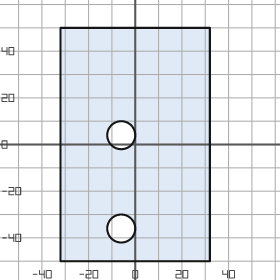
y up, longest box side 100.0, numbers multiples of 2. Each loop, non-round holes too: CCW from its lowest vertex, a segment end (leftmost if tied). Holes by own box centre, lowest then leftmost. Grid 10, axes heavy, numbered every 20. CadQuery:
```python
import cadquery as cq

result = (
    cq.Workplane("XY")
    .moveTo(-32.0, -50.0)
    .lineTo(32.0, -50.0)
    .lineTo(32.0, 50.0)
    .lineTo(-32.0, 50.0)
    .close()
    .moveTo(-6.0, -36.0)
    .circle(6.0)
    .moveTo(-6.0, 4.0)
    .circle(6.0)
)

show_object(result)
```